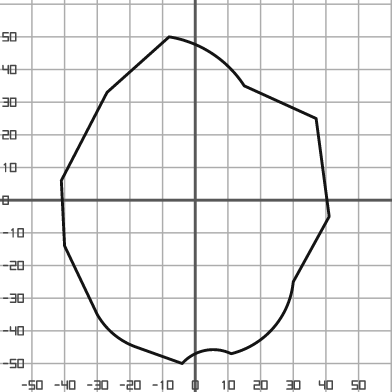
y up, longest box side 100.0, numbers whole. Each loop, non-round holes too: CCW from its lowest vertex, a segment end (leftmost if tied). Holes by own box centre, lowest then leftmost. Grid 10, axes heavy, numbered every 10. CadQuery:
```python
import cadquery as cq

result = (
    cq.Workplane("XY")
    .moveTo(-4.0, -50.0)
    .threePointArc((3.0, -46.0), (11.0, -47.0))
    .threePointArc((24.0, -39.0), (30.0, -25.0))
    .lineTo(41.0, -5.0)
    .lineTo(37.0, 25.0)
    .lineTo(15.0, 35.0)
    .threePointArc((5.0, 45.0), (-8.0, 50.0))
    .lineTo(-27.0, 33.0)
    .lineTo(-41.0, 6.0)
    .lineTo(-40.0, -14.0)
    .lineTo(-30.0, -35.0)
    .threePointArc((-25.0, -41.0), (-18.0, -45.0))
    .close()
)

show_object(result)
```